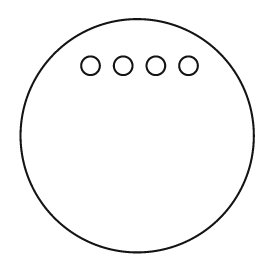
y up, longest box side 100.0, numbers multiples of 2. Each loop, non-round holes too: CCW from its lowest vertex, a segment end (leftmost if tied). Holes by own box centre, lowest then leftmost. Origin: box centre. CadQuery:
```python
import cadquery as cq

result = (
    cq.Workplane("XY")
    .moveTo(0.0, 0.0)
    .circle(50.0)
    .moveTo(-20.0, 30.0)
    .circle(4.0)
    .moveTo(-6.0, 30.0)
    .circle(4.0)
    .moveTo(8.0, 30.0)
    .circle(4.0)
    .moveTo(22.0, 30.0)
    .circle(4.0)
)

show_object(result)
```